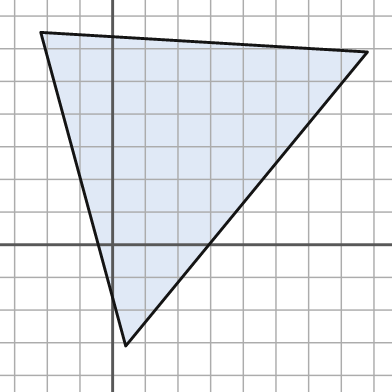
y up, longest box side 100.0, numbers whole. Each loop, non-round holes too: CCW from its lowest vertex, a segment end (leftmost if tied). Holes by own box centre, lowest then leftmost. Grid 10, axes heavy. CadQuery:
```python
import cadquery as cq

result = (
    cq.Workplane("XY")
    .moveTo(4.0, -31.0)
    .lineTo(78.0, 59.0)
    .lineTo(-22.0, 65.0)
    .close()
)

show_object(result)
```